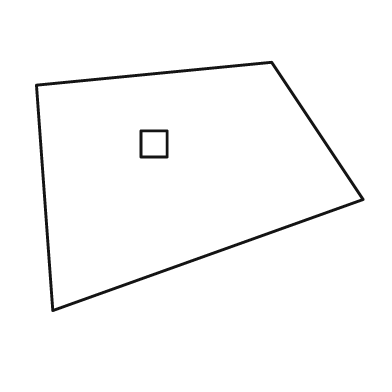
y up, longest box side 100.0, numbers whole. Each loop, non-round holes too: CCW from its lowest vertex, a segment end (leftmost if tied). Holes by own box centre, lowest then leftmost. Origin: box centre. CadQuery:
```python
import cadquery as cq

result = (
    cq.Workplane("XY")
    .moveTo(-45.0, -38.0)
    .lineTo(50.0, -4.0)
    .lineTo(22.0, 38.0)
    .lineTo(-50.0, 31.0)
    .close()
    .moveTo(-18.0, 9.0)
    .lineTo(-10.0, 9.0)
    .lineTo(-10.0, 17.0)
    .lineTo(-18.0, 17.0)
    .close()
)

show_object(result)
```